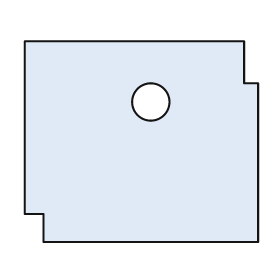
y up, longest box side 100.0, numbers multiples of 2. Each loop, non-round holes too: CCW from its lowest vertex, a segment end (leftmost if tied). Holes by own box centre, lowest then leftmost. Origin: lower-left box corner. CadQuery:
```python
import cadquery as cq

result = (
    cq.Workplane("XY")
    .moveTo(8.0, 0.0)
    .lineTo(100.0, 0.0)
    .lineTo(100.0, 68.0)
    .lineTo(94.0, 68.0)
    .lineTo(94.0, 86.0)
    .lineTo(0.0, 86.0)
    .lineTo(0.0, 12.0)
    .lineTo(8.0, 12.0)
    .close()
    .moveTo(54.0, 60.0)
    .circle(8.0)
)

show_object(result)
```